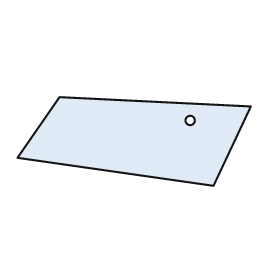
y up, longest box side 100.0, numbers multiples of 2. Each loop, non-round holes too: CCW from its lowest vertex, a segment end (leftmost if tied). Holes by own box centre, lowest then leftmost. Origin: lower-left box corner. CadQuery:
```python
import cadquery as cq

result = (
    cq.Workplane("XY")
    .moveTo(84.0, 0.0)
    .lineTo(100.0, 34.0)
    .lineTo(18.0, 38.0)
    .lineTo(0.0, 12.0)
    .close()
    .moveTo(74.0, 28.0)
    .circle(2.0)
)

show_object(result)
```